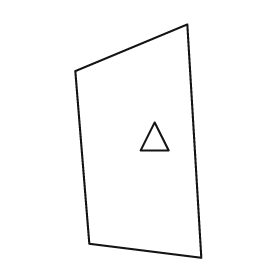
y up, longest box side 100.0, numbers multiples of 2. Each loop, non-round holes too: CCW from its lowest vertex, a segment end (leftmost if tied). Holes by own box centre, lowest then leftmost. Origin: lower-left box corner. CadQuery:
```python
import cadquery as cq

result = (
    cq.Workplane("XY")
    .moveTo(54.0, 0.0)
    .lineTo(48.0, 100.0)
    .lineTo(0.0, 80.0)
    .lineTo(6.0, 6.0)
    .close()
    .moveTo(28.0, 46.0)
    .lineTo(40.0, 46.0)
    .lineTo(34.0, 58.0)
    .close()
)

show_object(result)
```